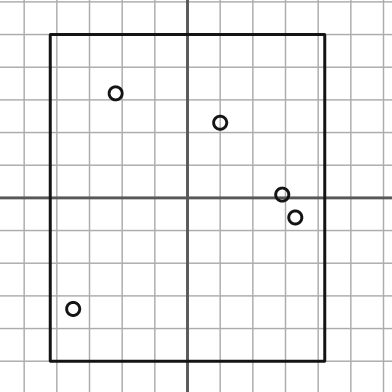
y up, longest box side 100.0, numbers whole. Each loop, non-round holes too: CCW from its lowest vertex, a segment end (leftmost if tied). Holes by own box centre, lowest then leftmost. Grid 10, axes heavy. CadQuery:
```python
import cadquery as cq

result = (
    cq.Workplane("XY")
    .moveTo(-42.0, -50.0)
    .lineTo(42.0, -50.0)
    .lineTo(42.0, 50.0)
    .lineTo(-42.0, 50.0)
    .close()
    .moveTo(-35.0, -34.0)
    .circle(2.0)
    .moveTo(33.0, -6.0)
    .circle(2.0)
    .moveTo(29.0, 1.0)
    .circle(2.0)
    .moveTo(10.0, 23.0)
    .circle(2.0)
    .moveTo(-22.0, 32.0)
    .circle(2.0)
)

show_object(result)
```